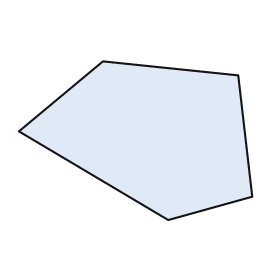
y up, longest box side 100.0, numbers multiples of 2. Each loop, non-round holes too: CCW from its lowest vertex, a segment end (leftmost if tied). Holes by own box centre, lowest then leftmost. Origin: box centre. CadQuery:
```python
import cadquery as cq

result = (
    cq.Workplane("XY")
    .moveTo(14.0, -34.0)
    .lineTo(50.0, -24.0)
    .lineTo(44.0, 28.0)
    .lineTo(-14.0, 34.0)
    .lineTo(-50.0, 4.0)
    .close()
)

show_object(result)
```